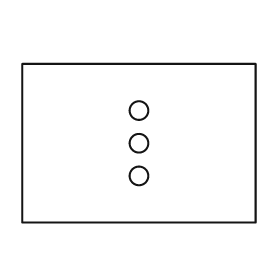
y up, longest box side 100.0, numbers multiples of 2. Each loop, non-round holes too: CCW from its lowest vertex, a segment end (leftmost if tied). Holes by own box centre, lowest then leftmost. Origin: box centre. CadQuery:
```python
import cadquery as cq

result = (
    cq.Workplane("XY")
    .moveTo(-50.0, -34.0)
    .lineTo(50.0, -34.0)
    .lineTo(50.0, 34.0)
    .lineTo(-50.0, 34.0)
    .close()
    .moveTo(0.0, -14.0)
    .circle(4.0)
    .moveTo(0.0, 0.0)
    .circle(4.0)
    .moveTo(0.0, 14.0)
    .circle(4.0)
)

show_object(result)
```